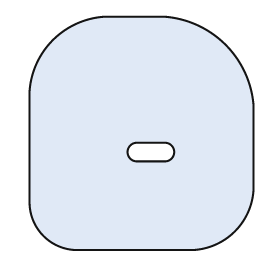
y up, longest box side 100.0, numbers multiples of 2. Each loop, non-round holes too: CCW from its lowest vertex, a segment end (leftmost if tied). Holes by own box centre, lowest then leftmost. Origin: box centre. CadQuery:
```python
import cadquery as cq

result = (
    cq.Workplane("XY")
    .moveTo(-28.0, -50.0)
    .lineTo(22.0, -50.0)
    .threePointArc((40.0, -42.0), (48.0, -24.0))
    .lineTo(48.0, 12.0)
    .threePointArc((36.0, 38.0), (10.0, 50.0))
    .lineTo(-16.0, 50.0)
    .threePointArc((-38.0, 40.0), (-48.0, 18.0))
    .lineTo(-48.0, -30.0)
    .threePointArc((-42.0, -44.0), (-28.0, -50.0))
    .close()
    .moveTo(-2.0, -12.0)
    .lineTo(10.0, -12.0)
    .threePointArc((14.0, -8.0), (10.0, -4.0))
    .lineTo(-2.0, -4.0)
    .threePointArc((-6.0, -8.0), (-2.0, -12.0))
    .close()
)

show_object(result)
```